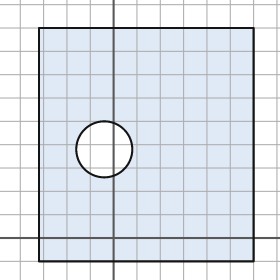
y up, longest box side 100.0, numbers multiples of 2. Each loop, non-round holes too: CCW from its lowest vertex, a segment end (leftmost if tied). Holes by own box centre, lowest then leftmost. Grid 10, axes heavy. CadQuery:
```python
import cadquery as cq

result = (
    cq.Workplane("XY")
    .moveTo(-32.0, -10.0)
    .lineTo(60.0, -10.0)
    .lineTo(60.0, 90.0)
    .lineTo(-32.0, 90.0)
    .close()
    .moveTo(-4.0, 38.0)
    .circle(12.0)
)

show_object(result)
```